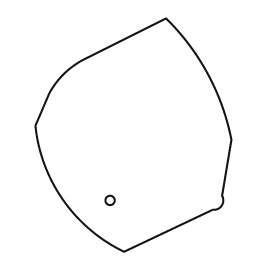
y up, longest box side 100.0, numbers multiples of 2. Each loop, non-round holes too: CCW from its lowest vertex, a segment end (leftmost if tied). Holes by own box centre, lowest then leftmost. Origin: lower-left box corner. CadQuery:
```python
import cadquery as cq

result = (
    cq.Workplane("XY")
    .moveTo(38.0, 0.0)
    .lineTo(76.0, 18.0)
    .threePointArc((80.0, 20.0), (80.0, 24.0))
    .lineTo(84.0, 48.0)
    .threePointArc((74.0, 76.0), (56.0, 100.0))
    .lineTo(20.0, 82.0)
    .threePointArc((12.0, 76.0), (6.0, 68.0))
    .lineTo(0.0, 54.0)
    .threePointArc((12.0, 22.0), (38.0, 0.0))
    .close()
    .moveTo(32.0, 22.0)
    .circle(2.0)
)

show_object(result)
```